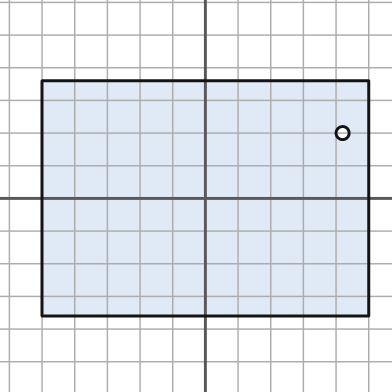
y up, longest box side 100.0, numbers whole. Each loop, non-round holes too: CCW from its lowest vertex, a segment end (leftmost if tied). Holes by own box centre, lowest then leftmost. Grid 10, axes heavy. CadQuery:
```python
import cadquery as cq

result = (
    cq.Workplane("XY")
    .moveTo(-50.0, -36.0)
    .lineTo(50.0, -36.0)
    .lineTo(50.0, 36.0)
    .lineTo(-50.0, 36.0)
    .close()
    .moveTo(42.0, 20.0)
    .circle(2.0)
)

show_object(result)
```